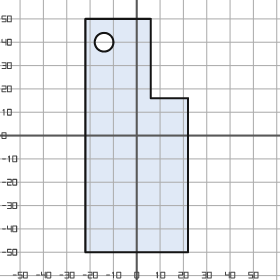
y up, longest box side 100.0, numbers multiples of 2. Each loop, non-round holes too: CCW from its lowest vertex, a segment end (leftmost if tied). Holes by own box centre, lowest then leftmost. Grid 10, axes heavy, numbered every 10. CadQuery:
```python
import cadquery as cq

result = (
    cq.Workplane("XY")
    .moveTo(-22.0, -50.0)
    .lineTo(22.0, -50.0)
    .lineTo(22.0, 16.0)
    .lineTo(6.0, 16.0)
    .lineTo(6.0, 50.0)
    .lineTo(-22.0, 50.0)
    .close()
    .moveTo(-14.0, 40.0)
    .circle(4.0)
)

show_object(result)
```